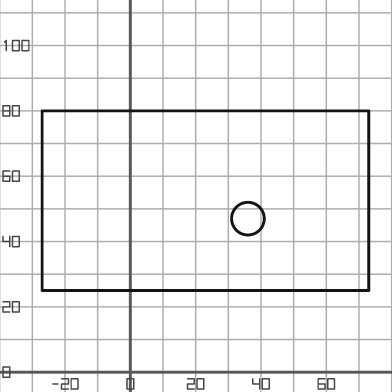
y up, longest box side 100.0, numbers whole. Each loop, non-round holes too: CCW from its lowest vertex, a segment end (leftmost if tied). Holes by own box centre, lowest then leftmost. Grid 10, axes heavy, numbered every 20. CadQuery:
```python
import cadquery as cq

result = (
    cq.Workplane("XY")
    .moveTo(-27.0, 25.0)
    .lineTo(73.0, 25.0)
    .lineTo(73.0, 80.0)
    .lineTo(-27.0, 80.0)
    .close()
    .moveTo(36.0, 47.0)
    .circle(5.0)
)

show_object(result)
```